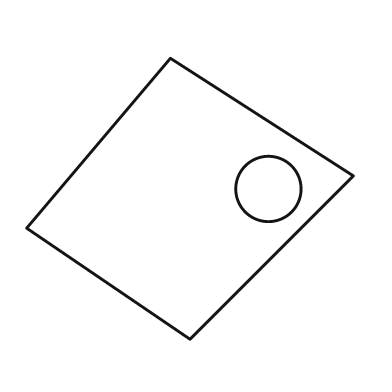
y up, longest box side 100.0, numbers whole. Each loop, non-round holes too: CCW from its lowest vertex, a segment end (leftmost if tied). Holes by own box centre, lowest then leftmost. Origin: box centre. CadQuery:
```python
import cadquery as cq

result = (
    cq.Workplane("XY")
    .moveTo(0.0, -43.0)
    .lineTo(50.0, 7.0)
    .lineTo(-6.0, 43.0)
    .lineTo(-50.0, -9.0)
    .close()
    .moveTo(24.0, 3.0)
    .circle(10.0)
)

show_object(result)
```